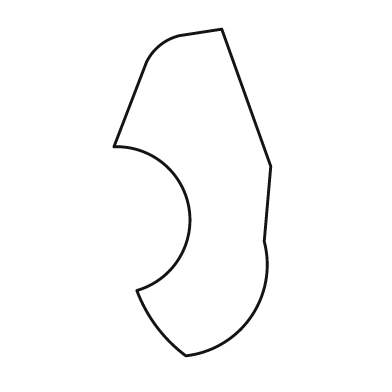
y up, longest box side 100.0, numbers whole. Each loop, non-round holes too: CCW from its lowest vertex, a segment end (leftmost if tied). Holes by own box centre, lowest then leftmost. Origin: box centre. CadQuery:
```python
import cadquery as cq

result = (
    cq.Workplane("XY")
    .moveTo(-2.0, -50.0)
    .threePointArc((18.0, -38.0), (22.0, -15.0))
    .lineTo(24.0, 8.0)
    .lineTo(9.0, 50.0)
    .lineTo(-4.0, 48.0)
    .threePointArc((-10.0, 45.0), (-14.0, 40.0))
    .lineTo(-24.0, 14.0)
    .threePointArc((-1.0, -5.0), (-17.0, -30.0))
    .threePointArc((-11.0, -41.0), (-2.0, -50.0))
    .close()
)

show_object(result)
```